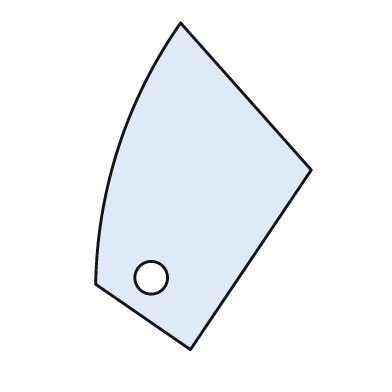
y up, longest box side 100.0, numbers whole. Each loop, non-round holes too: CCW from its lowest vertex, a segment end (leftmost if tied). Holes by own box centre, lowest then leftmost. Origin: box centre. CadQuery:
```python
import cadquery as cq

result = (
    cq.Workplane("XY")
    .moveTo(-4.0, -50.0)
    .lineTo(33.0, 5.0)
    .lineTo(-7.0, 50.0)
    .threePointArc((-26.0, 12.0), (-33.0, -30.0))
    .close()
    .moveTo(-16.0, -28.0)
    .circle(5.0)
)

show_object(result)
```